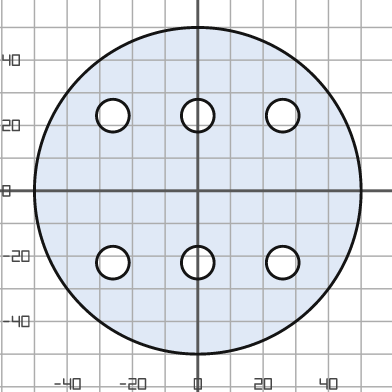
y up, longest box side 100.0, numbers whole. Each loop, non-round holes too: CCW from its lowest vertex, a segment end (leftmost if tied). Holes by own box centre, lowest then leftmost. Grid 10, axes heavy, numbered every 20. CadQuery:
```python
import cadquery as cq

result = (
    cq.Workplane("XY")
    .moveTo(0.0, 0.0)
    .circle(50.0)
    .moveTo(-26.0, -22.0)
    .circle(5.0)
    .moveTo(0.0, -22.0)
    .circle(5.0)
    .moveTo(26.0, -22.0)
    .circle(5.0)
    .moveTo(-26.0, 23.0)
    .circle(5.0)
    .moveTo(0.0, 23.0)
    .circle(5.0)
    .moveTo(26.0, 23.0)
    .circle(5.0)
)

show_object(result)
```